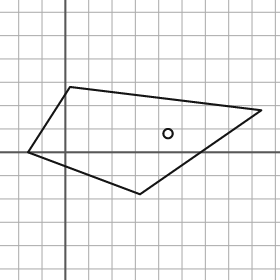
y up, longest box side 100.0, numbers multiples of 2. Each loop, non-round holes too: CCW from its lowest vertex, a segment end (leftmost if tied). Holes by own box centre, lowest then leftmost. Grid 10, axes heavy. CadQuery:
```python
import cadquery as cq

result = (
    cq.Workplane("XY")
    .moveTo(32.0, -18.0)
    .lineTo(84.0, 18.0)
    .lineTo(2.0, 28.0)
    .lineTo(-16.0, 0.0)
    .close()
    .moveTo(44.0, 8.0)
    .circle(2.0)
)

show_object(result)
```